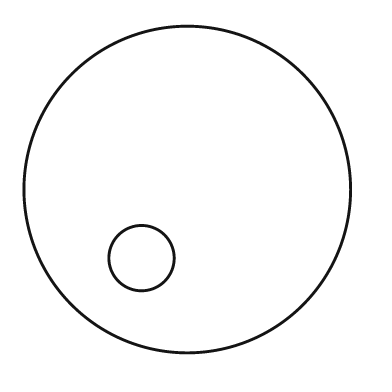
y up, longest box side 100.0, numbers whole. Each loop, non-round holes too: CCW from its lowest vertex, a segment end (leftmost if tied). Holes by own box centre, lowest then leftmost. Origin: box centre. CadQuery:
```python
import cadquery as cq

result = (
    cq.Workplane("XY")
    .moveTo(0.0, 0.0)
    .circle(50.0)
    .moveTo(-14.0, -21.0)
    .circle(10.0)
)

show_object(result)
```